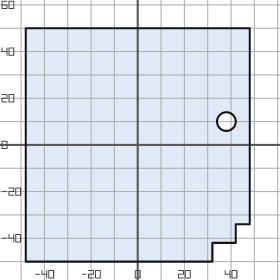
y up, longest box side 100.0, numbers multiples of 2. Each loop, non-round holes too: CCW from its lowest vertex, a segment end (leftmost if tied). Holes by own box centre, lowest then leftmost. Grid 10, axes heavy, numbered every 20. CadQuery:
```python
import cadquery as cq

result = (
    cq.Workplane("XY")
    .moveTo(-48.0, -50.0)
    .lineTo(32.0, -50.0)
    .lineTo(32.0, -42.0)
    .lineTo(42.0, -42.0)
    .lineTo(42.0, -34.0)
    .lineTo(48.0, -34.0)
    .lineTo(48.0, 50.0)
    .lineTo(-48.0, 50.0)
    .close()
    .moveTo(38.0, 10.0)
    .circle(4.0)
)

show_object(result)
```